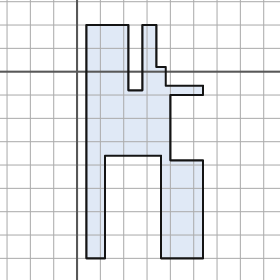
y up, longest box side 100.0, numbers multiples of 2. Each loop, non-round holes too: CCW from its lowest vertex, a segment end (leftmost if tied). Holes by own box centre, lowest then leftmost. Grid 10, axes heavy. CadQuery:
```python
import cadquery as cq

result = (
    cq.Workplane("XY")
    .moveTo(4.0, -80.0)
    .lineTo(12.0, -80.0)
    .lineTo(12.0, -36.0)
    .lineTo(36.0, -36.0)
    .lineTo(36.0, -80.0)
    .lineTo(54.0, -80.0)
    .lineTo(54.0, -38.0)
    .lineTo(40.0, -38.0)
    .lineTo(40.0, -10.0)
    .lineTo(54.0, -10.0)
    .lineTo(54.0, -6.0)
    .lineTo(38.0, -6.0)
    .lineTo(38.0, 2.0)
    .lineTo(34.0, 2.0)
    .lineTo(34.0, 20.0)
    .lineTo(28.0, 20.0)
    .lineTo(28.0, -8.0)
    .lineTo(22.0, -8.0)
    .lineTo(22.0, 20.0)
    .lineTo(4.0, 20.0)
    .close()
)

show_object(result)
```